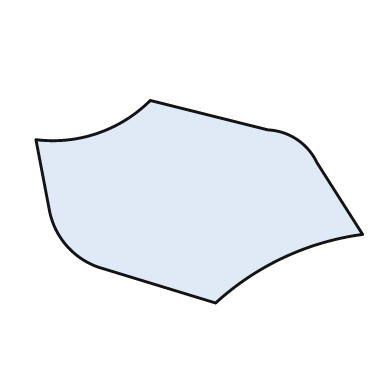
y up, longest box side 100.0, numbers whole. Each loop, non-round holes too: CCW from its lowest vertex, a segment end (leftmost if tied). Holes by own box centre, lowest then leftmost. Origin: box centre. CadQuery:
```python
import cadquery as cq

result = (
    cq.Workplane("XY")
    .moveTo(5.0, -31.0)
    .threePointArc((26.0, -17.0), (50.0, -10.0))
    .lineTo(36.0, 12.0)
    .threePointArc((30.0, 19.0), (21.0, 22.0))
    .lineTo(-15.0, 31.0)
    .threePointArc((-31.0, 21.0), (-50.0, 19.0))
    .lineTo(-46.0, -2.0)
    .threePointArc((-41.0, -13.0), (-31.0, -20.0))
    .close()
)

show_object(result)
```